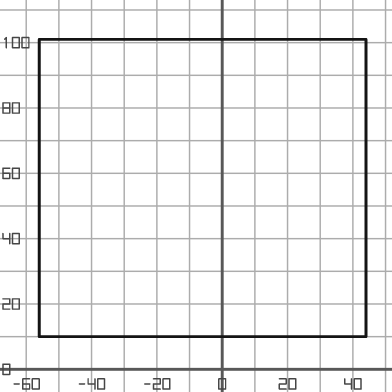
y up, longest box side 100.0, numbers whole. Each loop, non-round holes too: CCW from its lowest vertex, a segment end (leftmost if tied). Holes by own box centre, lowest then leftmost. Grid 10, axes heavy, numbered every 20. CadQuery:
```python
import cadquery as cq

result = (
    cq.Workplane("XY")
    .moveTo(-56.0, 10.0)
    .lineTo(44.0, 10.0)
    .lineTo(44.0, 101.0)
    .lineTo(-56.0, 101.0)
    .close()
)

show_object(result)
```